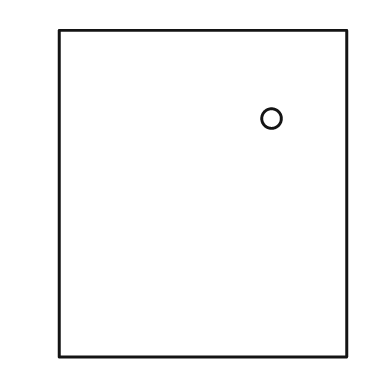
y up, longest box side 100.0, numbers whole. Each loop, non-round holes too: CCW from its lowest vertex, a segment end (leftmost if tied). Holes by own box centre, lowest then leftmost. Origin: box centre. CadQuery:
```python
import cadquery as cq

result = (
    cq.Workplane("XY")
    .moveTo(-44.0, -50.0)
    .lineTo(44.0, -50.0)
    .lineTo(44.0, 50.0)
    .lineTo(-44.0, 50.0)
    .close()
    .moveTo(21.0, 23.0)
    .circle(3.0)
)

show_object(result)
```